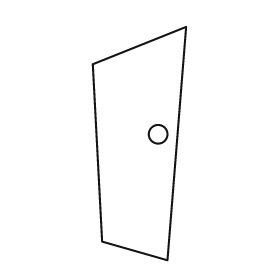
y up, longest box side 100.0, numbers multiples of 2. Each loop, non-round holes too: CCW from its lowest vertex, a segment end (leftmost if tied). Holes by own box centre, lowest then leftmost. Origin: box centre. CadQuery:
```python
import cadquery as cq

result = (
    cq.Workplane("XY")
    .moveTo(12.0, -50.0)
    .lineTo(20.0, 50.0)
    .lineTo(-20.0, 34.0)
    .lineTo(-16.0, -42.0)
    .close()
    .moveTo(8.0, 4.0)
    .circle(4.0)
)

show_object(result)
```